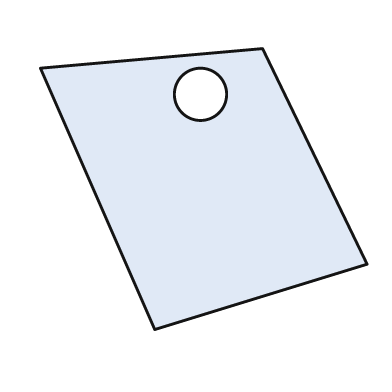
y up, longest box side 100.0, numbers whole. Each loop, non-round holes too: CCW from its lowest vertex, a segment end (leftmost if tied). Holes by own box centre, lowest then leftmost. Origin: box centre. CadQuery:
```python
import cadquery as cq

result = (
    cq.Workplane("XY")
    .moveTo(-15.0, -43.0)
    .lineTo(50.0, -23.0)
    .lineTo(18.0, 43.0)
    .lineTo(-50.0, 37.0)
    .close()
    .moveTo(-1.0, 29.0)
    .circle(8.0)
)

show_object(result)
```